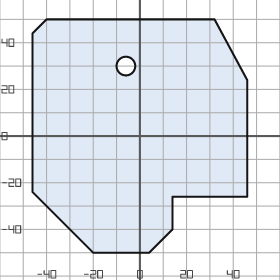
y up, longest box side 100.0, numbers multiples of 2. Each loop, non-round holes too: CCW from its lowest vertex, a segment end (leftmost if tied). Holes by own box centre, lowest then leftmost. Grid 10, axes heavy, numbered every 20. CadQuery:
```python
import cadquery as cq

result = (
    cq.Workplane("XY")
    .moveTo(-20.0, -50.0)
    .lineTo(4.0, -50.0)
    .lineTo(14.0, -40.0)
    .lineTo(14.0, -26.0)
    .lineTo(46.0, -26.0)
    .lineTo(46.0, 24.0)
    .lineTo(32.0, 50.0)
    .lineTo(-40.0, 50.0)
    .lineTo(-46.0, 44.0)
    .lineTo(-46.0, -24.0)
    .close()
    .moveTo(-6.0, 30.0)
    .circle(4.0)
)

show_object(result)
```